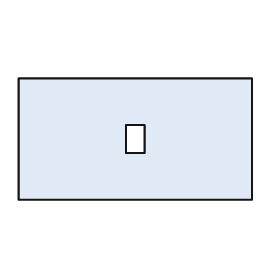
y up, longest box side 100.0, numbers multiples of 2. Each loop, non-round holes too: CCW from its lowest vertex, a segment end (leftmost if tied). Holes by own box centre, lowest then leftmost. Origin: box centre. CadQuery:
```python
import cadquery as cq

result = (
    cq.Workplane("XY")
    .moveTo(-50.0, -26.0)
    .lineTo(50.0, -26.0)
    .lineTo(50.0, 26.0)
    .lineTo(-50.0, 26.0)
    .close()
    .moveTo(-4.0, -6.0)
    .lineTo(4.0, -6.0)
    .lineTo(4.0, 6.0)
    .lineTo(-4.0, 6.0)
    .close()
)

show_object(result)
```